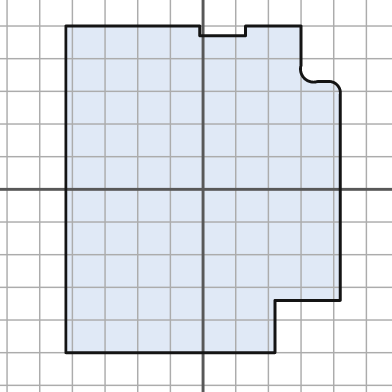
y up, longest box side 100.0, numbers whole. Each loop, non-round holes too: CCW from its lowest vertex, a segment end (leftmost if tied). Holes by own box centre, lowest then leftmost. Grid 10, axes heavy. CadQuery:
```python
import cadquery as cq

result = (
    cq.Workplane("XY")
    .moveTo(-42.0, -50.0)
    .lineTo(22.0, -50.0)
    .lineTo(22.0, -34.0)
    .lineTo(42.0, -34.0)
    .lineTo(42.0, 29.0)
    .threePointArc((41.0, 32.0), (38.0, 33.0))
    .lineTo(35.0, 33.0)
    .threePointArc((31.0, 34.0), (30.0, 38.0))
    .lineTo(30.0, 50.0)
    .lineTo(13.0, 50.0)
    .lineTo(13.0, 47.0)
    .lineTo(-1.0, 47.0)
    .lineTo(-1.0, 50.0)
    .lineTo(-42.0, 50.0)
    .close()
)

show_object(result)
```